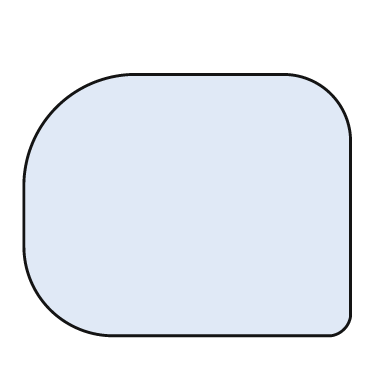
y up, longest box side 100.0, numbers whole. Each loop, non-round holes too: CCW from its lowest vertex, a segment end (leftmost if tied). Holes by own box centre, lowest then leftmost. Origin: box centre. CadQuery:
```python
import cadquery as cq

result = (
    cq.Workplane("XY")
    .moveTo(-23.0, -40.0)
    .lineTo(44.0, -40.0)
    .threePointArc((48.0, -38.0), (50.0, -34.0))
    .lineTo(50.0, 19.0)
    .threePointArc((44.0, 34.0), (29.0, 40.0))
    .lineTo(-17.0, 40.0)
    .threePointArc((-40.0, 30.0), (-50.0, 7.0))
    .lineTo(-50.0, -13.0)
    .threePointArc((-42.0, -32.0), (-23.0, -40.0))
    .close()
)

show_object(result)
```